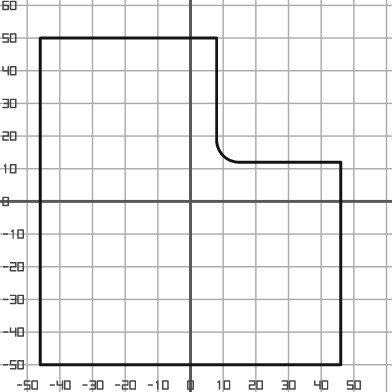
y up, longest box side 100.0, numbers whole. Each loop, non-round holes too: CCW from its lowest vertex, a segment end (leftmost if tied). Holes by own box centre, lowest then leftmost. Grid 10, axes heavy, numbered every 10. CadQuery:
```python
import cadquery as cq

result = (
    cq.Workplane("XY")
    .moveTo(-46.0, -50.0)
    .lineTo(46.0, -50.0)
    .lineTo(46.0, 12.0)
    .lineTo(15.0, 12.0)
    .threePointArc((10.0, 14.0), (8.0, 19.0))
    .lineTo(8.0, 50.0)
    .lineTo(-46.0, 50.0)
    .close()
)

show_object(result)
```